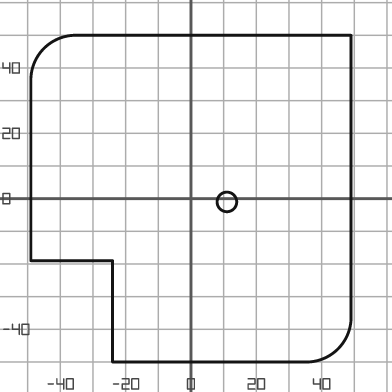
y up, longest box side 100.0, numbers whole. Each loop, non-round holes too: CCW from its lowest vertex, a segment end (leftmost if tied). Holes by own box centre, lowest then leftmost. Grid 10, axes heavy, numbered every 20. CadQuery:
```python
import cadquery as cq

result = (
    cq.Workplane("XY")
    .moveTo(-24.0, -50.0)
    .lineTo(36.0, -50.0)
    .threePointArc((45.0, -46.0), (49.0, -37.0))
    .lineTo(49.0, 50.0)
    .lineTo(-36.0, 50.0)
    .threePointArc((-45.0, 46.0), (-49.0, 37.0))
    .lineTo(-49.0, -19.0)
    .lineTo(-24.0, -19.0)
    .close()
    .moveTo(11.0, -1.0)
    .circle(3.0)
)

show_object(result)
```